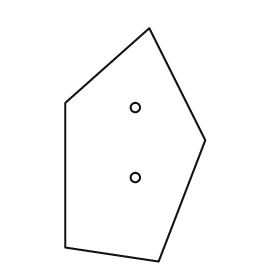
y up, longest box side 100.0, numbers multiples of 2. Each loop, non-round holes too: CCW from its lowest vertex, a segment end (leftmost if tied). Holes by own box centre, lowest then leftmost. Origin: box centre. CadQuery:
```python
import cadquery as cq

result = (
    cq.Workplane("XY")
    .moveTo(10.0, -50.0)
    .lineTo(30.0, 2.0)
    .lineTo(6.0, 50.0)
    .lineTo(-30.0, 18.0)
    .lineTo(-30.0, -44.0)
    .close()
    .moveTo(0.0, -14.0)
    .circle(2.0)
    .moveTo(0.0, 16.0)
    .circle(2.0)
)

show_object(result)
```